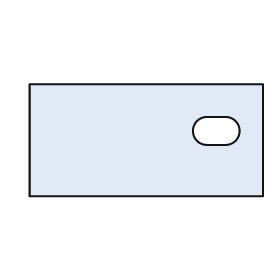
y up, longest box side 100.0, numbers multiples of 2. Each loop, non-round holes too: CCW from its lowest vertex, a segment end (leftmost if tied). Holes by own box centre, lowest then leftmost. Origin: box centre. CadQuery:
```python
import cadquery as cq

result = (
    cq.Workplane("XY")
    .moveTo(-50.0, -24.0)
    .lineTo(50.0, -24.0)
    .lineTo(50.0, 24.0)
    .lineTo(-50.0, 24.0)
    .close()
    .moveTo(26.0, -2.0)
    .lineTo(34.0, -2.0)
    .threePointArc((40.0, 4.0), (34.0, 10.0))
    .lineTo(26.0, 10.0)
    .threePointArc((20.0, 4.0), (26.0, -2.0))
    .close()
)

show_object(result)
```